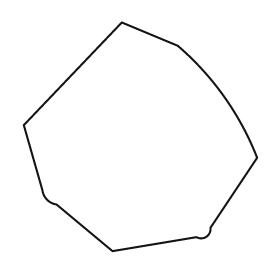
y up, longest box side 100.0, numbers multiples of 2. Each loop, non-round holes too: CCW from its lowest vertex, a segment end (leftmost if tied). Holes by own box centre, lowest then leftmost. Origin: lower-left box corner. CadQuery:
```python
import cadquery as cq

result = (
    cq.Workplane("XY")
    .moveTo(38.0, 0.0)
    .lineTo(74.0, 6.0)
    .threePointArc((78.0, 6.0), (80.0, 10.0))
    .lineTo(100.0, 40.0)
    .threePointArc((86.0, 66.0), (66.0, 88.0))
    .lineTo(42.0, 98.0)
    .lineTo(0.0, 54.0)
    .lineTo(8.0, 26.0)
    .threePointArc((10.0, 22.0), (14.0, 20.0))
    .close()
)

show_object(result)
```